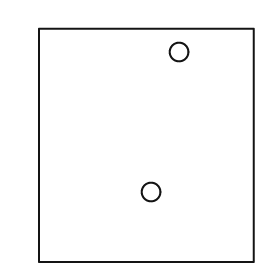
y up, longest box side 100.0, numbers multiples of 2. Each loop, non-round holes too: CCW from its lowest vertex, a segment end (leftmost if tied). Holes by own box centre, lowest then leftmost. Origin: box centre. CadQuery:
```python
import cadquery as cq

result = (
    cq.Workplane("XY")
    .moveTo(-46.0, -50.0)
    .lineTo(46.0, -50.0)
    .lineTo(46.0, 50.0)
    .lineTo(-46.0, 50.0)
    .close()
    .moveTo(2.0, -20.0)
    .circle(4.0)
    .moveTo(14.0, 40.0)
    .circle(4.0)
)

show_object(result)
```